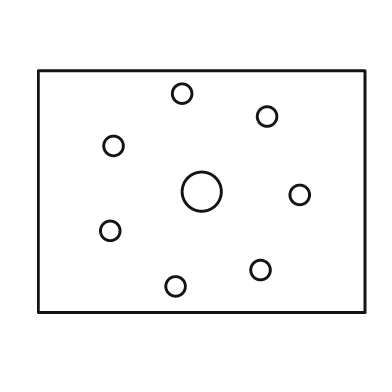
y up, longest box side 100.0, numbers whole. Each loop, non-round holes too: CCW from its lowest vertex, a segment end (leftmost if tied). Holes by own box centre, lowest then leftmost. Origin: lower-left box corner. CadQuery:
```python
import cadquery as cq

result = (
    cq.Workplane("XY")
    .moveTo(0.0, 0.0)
    .lineTo(100.0, 0.0)
    .lineTo(100.0, 74.0)
    .lineTo(0.0, 74.0)
    .close()
    .moveTo(42.0, 8.0)
    .circle(3.0)
    .moveTo(68.0, 13.0)
    .circle(3.0)
    .moveTo(22.0, 25.0)
    .circle(3.0)
    .moveTo(80.0, 36.0)
    .circle(3.0)
    .moveTo(50.0, 37.0)
    .circle(6.0)
    .moveTo(23.0, 51.0)
    .circle(3.0)
    .moveTo(70.0, 60.0)
    .circle(3.0)
    .moveTo(44.0, 67.0)
    .circle(3.0)
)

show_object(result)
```